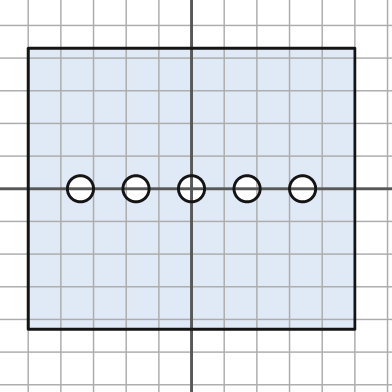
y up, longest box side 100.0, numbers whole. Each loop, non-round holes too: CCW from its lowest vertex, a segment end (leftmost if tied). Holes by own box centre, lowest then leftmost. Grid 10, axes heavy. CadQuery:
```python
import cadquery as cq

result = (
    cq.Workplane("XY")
    .moveTo(-50.0, -43.0)
    .lineTo(50.0, -43.0)
    .lineTo(50.0, 43.0)
    .lineTo(-50.0, 43.0)
    .close()
    .moveTo(-34.0, 0.0)
    .circle(4.0)
    .moveTo(-17.0, 0.0)
    .circle(4.0)
    .moveTo(0.0, 0.0)
    .circle(4.0)
    .moveTo(17.0, 0.0)
    .circle(4.0)
    .moveTo(34.0, 0.0)
    .circle(4.0)
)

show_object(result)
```